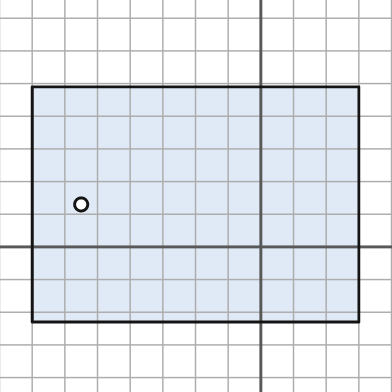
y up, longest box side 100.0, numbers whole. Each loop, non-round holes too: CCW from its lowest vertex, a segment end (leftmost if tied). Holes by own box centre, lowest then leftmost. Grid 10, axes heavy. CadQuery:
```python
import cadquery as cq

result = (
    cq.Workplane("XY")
    .moveTo(-70.0, -23.0)
    .lineTo(30.0, -23.0)
    .lineTo(30.0, 49.0)
    .lineTo(-70.0, 49.0)
    .close()
    .moveTo(-55.0, 13.0)
    .circle(2.0)
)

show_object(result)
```